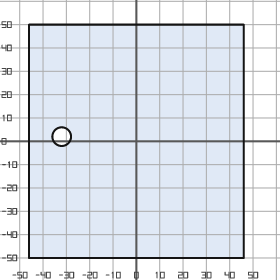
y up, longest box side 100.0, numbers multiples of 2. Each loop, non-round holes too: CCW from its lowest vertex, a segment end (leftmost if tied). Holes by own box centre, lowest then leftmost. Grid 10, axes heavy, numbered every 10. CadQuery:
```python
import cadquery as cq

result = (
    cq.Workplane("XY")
    .moveTo(-46.0, -50.0)
    .lineTo(46.0, -50.0)
    .lineTo(46.0, 50.0)
    .lineTo(-46.0, 50.0)
    .close()
    .moveTo(-32.0, 2.0)
    .circle(4.0)
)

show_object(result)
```